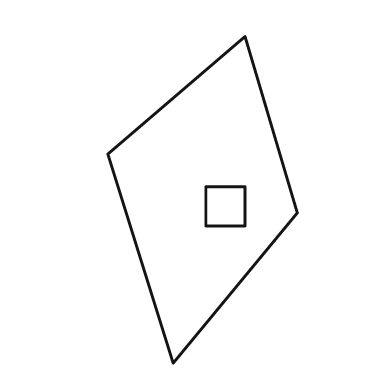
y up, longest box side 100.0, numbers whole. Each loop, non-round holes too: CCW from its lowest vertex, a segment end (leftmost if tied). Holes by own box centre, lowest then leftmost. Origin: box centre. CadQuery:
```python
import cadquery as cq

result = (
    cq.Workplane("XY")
    .moveTo(-9.0, -50.0)
    .lineTo(29.0, -4.0)
    .lineTo(13.0, 50.0)
    .lineTo(-29.0, 14.0)
    .close()
    .moveTo(1.0, -8.0)
    .lineTo(13.0, -8.0)
    .lineTo(13.0, 4.0)
    .lineTo(1.0, 4.0)
    .close()
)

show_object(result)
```